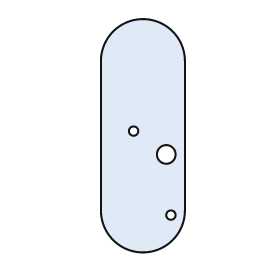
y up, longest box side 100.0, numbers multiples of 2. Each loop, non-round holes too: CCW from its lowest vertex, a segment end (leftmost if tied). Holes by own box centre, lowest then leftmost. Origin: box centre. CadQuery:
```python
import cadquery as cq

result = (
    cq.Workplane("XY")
    .moveTo(-18.0, -32.0)
    .threePointArc((0.0, -50.0), (18.0, -32.0))
    .lineTo(18.0, 32.0)
    .threePointArc((0.0, 50.0), (-18.0, 32.0))
    .close()
    .moveTo(12.0, -34.0)
    .circle(2.0)
    .moveTo(10.0, -8.0)
    .circle(4.0)
    .moveTo(-4.0, 2.0)
    .circle(2.0)
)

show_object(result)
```